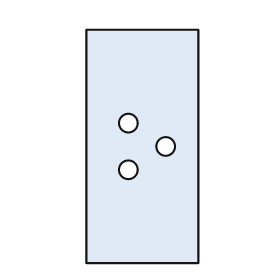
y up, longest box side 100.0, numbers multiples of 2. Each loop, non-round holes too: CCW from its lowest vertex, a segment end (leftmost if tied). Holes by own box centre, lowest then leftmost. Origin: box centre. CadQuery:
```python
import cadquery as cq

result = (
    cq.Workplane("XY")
    .moveTo(-24.0, -50.0)
    .lineTo(24.0, -50.0)
    .lineTo(24.0, 50.0)
    .lineTo(-24.0, 50.0)
    .close()
    .moveTo(-6.0, -10.0)
    .circle(4.0)
    .moveTo(10.0, 0.0)
    .circle(4.0)
    .moveTo(-6.0, 10.0)
    .circle(4.0)
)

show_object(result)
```